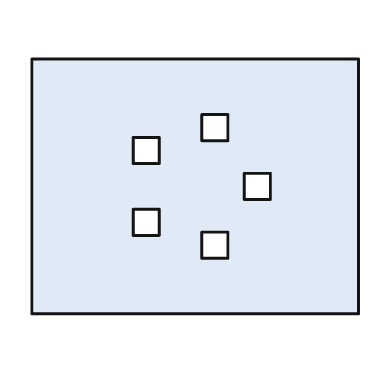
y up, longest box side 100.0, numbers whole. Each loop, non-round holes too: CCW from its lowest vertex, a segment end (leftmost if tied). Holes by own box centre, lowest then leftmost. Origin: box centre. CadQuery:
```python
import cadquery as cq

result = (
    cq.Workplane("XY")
    .moveTo(-50.0, -39.0)
    .lineTo(50.0, -39.0)
    .lineTo(50.0, 39.0)
    .lineTo(-50.0, 39.0)
    .close()
    .moveTo(2.0, -22.0)
    .lineTo(10.0, -22.0)
    .lineTo(10.0, -14.0)
    .lineTo(2.0, -14.0)
    .close()
    .moveTo(-19.0, -15.0)
    .lineTo(-11.0, -15.0)
    .lineTo(-11.0, -7.0)
    .lineTo(-19.0, -7.0)
    .close()
    .moveTo(15.0, -4.0)
    .lineTo(23.0, -4.0)
    .lineTo(23.0, 4.0)
    .lineTo(15.0, 4.0)
    .close()
    .moveTo(-19.0, 7.0)
    .lineTo(-11.0, 7.0)
    .lineTo(-11.0, 15.0)
    .lineTo(-19.0, 15.0)
    .close()
    .moveTo(2.0, 14.0)
    .lineTo(10.0, 14.0)
    .lineTo(10.0, 22.0)
    .lineTo(2.0, 22.0)
    .close()
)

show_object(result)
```